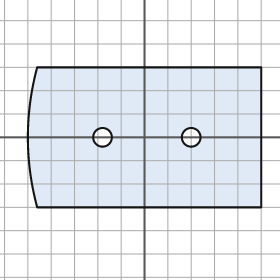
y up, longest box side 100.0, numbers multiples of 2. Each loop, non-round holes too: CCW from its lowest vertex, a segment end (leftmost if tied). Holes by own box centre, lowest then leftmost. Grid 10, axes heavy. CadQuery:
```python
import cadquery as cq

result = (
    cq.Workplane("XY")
    .moveTo(-46.0, -30.0)
    .lineTo(50.0, -30.0)
    .lineTo(50.0, 30.0)
    .lineTo(-46.0, 30.0)
    .threePointArc((-50.0, 0.0), (-46.0, -30.0))
    .close()
    .moveTo(-18.0, 0.0)
    .circle(4.0)
    .moveTo(20.0, 0.0)
    .circle(4.0)
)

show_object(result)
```